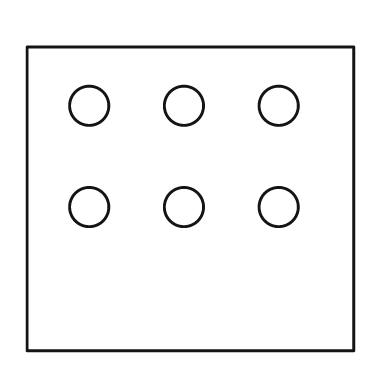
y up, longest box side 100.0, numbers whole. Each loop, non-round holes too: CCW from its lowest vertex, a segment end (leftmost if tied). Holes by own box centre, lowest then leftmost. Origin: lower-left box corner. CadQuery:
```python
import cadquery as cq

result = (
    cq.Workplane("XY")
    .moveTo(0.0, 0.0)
    .lineTo(100.0, 0.0)
    .lineTo(100.0, 93.0)
    .lineTo(0.0, 93.0)
    .close()
    .moveTo(19.0, 44.0)
    .circle(6.0)
    .moveTo(48.0, 44.0)
    .circle(6.0)
    .moveTo(77.0, 44.0)
    .circle(6.0)
    .moveTo(19.0, 75.0)
    .circle(6.0)
    .moveTo(48.0, 75.0)
    .circle(6.0)
    .moveTo(77.0, 75.0)
    .circle(6.0)
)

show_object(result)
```